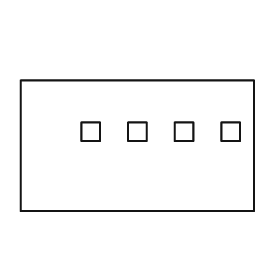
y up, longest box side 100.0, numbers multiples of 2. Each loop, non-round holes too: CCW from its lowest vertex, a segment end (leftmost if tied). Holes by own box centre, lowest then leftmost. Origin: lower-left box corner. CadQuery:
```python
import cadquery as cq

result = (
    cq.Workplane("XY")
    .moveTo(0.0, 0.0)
    .lineTo(100.0, 0.0)
    .lineTo(100.0, 56.0)
    .lineTo(0.0, 56.0)
    .close()
    .moveTo(26.0, 30.0)
    .lineTo(34.0, 30.0)
    .lineTo(34.0, 38.0)
    .lineTo(26.0, 38.0)
    .close()
    .moveTo(46.0, 30.0)
    .lineTo(54.0, 30.0)
    .lineTo(54.0, 38.0)
    .lineTo(46.0, 38.0)
    .close()
    .moveTo(66.0, 30.0)
    .lineTo(74.0, 30.0)
    .lineTo(74.0, 38.0)
    .lineTo(66.0, 38.0)
    .close()
    .moveTo(86.0, 30.0)
    .lineTo(94.0, 30.0)
    .lineTo(94.0, 38.0)
    .lineTo(86.0, 38.0)
    .close()
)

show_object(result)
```